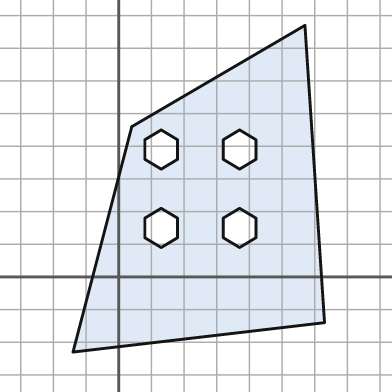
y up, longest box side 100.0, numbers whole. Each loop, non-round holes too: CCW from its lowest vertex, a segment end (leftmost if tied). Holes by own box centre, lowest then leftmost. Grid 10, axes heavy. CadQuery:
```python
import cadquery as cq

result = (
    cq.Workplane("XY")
    .moveTo(-14.0, -23.0)
    .lineTo(63.0, -14.0)
    .lineTo(57.0, 77.0)
    .lineTo(4.0, 46.0)
    .close()
    .moveTo(13.0, 9.0)
    .lineTo(18.0, 12.0)
    .lineTo(18.0, 18.0)
    .lineTo(13.0, 21.0)
    .lineTo(8.0, 18.0)
    .lineTo(8.0, 12.0)
    .close()
    .moveTo(37.0, 9.0)
    .lineTo(42.0, 12.0)
    .lineTo(42.0, 18.0)
    .lineTo(37.0, 21.0)
    .lineTo(32.0, 18.0)
    .lineTo(32.0, 12.0)
    .close()
    .moveTo(13.0, 33.0)
    .lineTo(18.0, 36.0)
    .lineTo(18.0, 42.0)
    .lineTo(13.0, 45.0)
    .lineTo(8.0, 42.0)
    .lineTo(8.0, 36.0)
    .close()
    .moveTo(37.0, 33.0)
    .lineTo(42.0, 36.0)
    .lineTo(42.0, 42.0)
    .lineTo(37.0, 45.0)
    .lineTo(32.0, 42.0)
    .lineTo(32.0, 36.0)
    .close()
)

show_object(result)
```